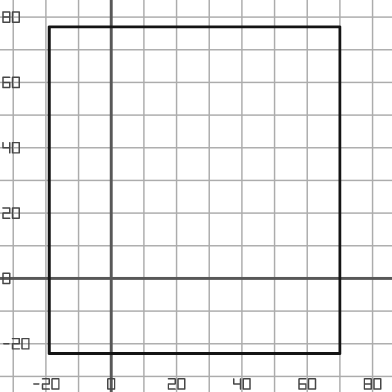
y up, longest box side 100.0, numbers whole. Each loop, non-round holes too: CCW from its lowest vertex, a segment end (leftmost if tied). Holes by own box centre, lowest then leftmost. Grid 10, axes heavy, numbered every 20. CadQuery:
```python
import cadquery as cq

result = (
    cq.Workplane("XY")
    .moveTo(-19.0, -23.0)
    .lineTo(70.0, -23.0)
    .lineTo(70.0, 77.0)
    .lineTo(-19.0, 77.0)
    .close()
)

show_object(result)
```